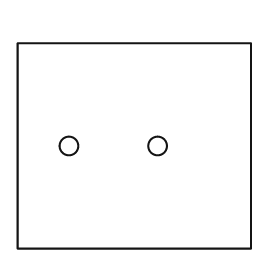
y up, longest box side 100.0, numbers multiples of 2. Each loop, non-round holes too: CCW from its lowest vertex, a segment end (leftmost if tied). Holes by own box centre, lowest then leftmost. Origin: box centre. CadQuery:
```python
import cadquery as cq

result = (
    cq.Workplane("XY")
    .moveTo(-50.0, -44.0)
    .lineTo(50.0, -44.0)
    .lineTo(50.0, 44.0)
    .lineTo(-50.0, 44.0)
    .close()
    .moveTo(-28.0, 0.0)
    .circle(4.0)
    .moveTo(10.0, 0.0)
    .circle(4.0)
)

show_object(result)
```